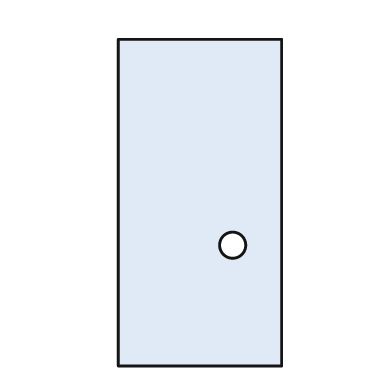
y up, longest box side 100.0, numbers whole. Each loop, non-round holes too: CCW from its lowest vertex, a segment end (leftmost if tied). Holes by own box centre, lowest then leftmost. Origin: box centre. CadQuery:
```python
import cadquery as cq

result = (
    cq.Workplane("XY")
    .moveTo(-25.0, -50.0)
    .lineTo(25.0, -50.0)
    .lineTo(25.0, 50.0)
    .lineTo(-25.0, 50.0)
    .close()
    .moveTo(10.0, -13.0)
    .circle(4.0)
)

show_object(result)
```